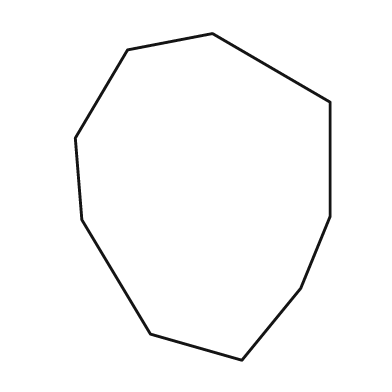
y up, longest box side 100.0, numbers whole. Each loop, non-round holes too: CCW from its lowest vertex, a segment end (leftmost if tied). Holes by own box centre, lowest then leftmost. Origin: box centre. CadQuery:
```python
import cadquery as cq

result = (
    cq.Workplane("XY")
    .moveTo(12.0, -50.0)
    .lineTo(30.0, -28.0)
    .lineTo(39.0, -6.0)
    .lineTo(39.0, 29.0)
    .lineTo(3.0, 50.0)
    .lineTo(-23.0, 45.0)
    .lineTo(-39.0, 18.0)
    .lineTo(-37.0, -7.0)
    .lineTo(-16.0, -42.0)
    .close()
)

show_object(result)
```